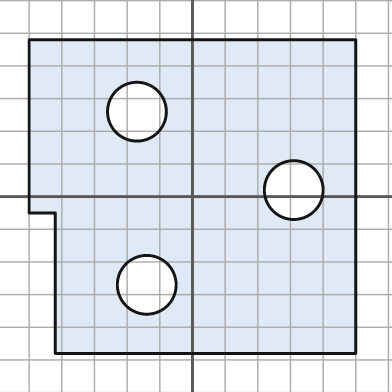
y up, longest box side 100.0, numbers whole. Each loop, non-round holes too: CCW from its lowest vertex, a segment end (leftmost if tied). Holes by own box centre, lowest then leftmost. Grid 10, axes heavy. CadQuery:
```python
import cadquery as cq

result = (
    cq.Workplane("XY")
    .moveTo(-42.0, -48.0)
    .lineTo(50.0, -48.0)
    .lineTo(50.0, 48.0)
    .lineTo(-50.0, 48.0)
    .lineTo(-50.0, -5.0)
    .lineTo(-42.0, -5.0)
    .close()
    .moveTo(-14.0, -27.0)
    .circle(9.0)
    .moveTo(31.0, 2.0)
    .circle(9.0)
    .moveTo(-17.0, 26.0)
    .circle(9.0)
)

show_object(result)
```